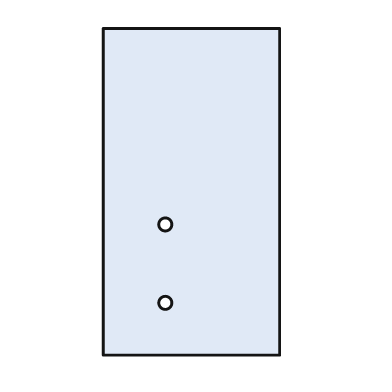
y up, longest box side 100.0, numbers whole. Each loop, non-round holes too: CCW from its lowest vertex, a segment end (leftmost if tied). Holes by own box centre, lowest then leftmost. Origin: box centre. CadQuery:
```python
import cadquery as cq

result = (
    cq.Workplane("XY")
    .moveTo(-27.0, -50.0)
    .lineTo(27.0, -50.0)
    .lineTo(27.0, 50.0)
    .lineTo(-27.0, 50.0)
    .close()
    .moveTo(-8.0, -34.0)
    .circle(2.0)
    .moveTo(-8.0, -10.0)
    .circle(2.0)
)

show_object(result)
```